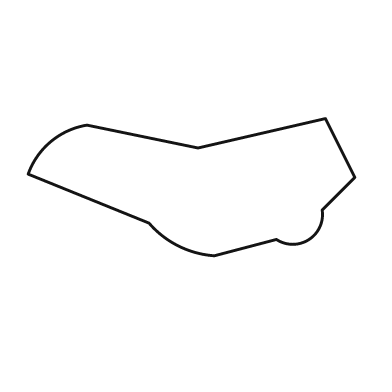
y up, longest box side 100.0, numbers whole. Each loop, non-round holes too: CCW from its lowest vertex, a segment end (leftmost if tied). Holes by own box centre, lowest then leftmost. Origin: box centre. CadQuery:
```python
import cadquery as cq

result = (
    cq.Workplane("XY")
    .moveTo(7.0, -21.0)
    .lineTo(26.0, -16.0)
    .threePointArc((36.0, -16.0), (40.0, -7.0))
    .lineTo(50.0, 3.0)
    .lineTo(41.0, 21.0)
    .lineTo(2.0, 12.0)
    .lineTo(-32.0, 19.0)
    .threePointArc((-43.0, 14.0), (-50.0, 4.0))
    .lineTo(-13.0, -11.0)
    .threePointArc((-4.0, -18.0), (7.0, -21.0))
    .close()
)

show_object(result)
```